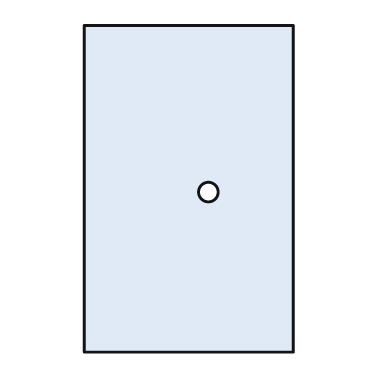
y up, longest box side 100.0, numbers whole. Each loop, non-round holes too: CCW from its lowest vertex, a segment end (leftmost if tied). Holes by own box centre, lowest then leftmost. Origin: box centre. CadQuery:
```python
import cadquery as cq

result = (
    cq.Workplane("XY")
    .moveTo(-32.0, -50.0)
    .lineTo(32.0, -50.0)
    .lineTo(32.0, 50.0)
    .lineTo(-32.0, 50.0)
    .close()
    .moveTo(6.0, -1.0)
    .circle(3.0)
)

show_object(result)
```